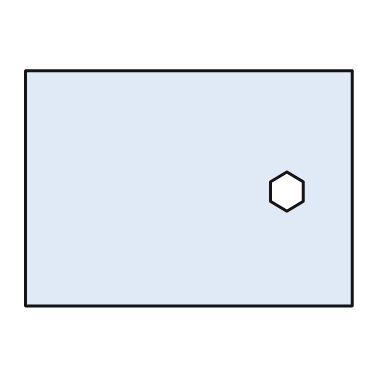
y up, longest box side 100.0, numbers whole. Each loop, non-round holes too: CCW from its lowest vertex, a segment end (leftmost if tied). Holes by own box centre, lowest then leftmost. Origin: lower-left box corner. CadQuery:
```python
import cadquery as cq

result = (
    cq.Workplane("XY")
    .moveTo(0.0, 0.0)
    .lineTo(100.0, 0.0)
    .lineTo(100.0, 72.0)
    .lineTo(0.0, 72.0)
    .close()
    .moveTo(80.0, 29.0)
    .lineTo(85.0, 32.0)
    .lineTo(85.0, 38.0)
    .lineTo(80.0, 41.0)
    .lineTo(75.0, 38.0)
    .lineTo(75.0, 32.0)
    .close()
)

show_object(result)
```